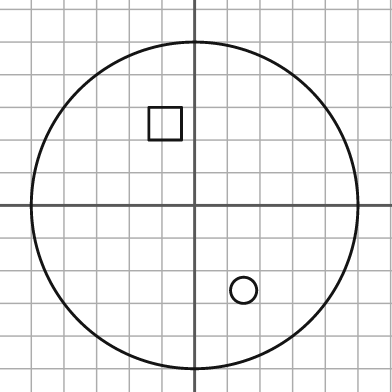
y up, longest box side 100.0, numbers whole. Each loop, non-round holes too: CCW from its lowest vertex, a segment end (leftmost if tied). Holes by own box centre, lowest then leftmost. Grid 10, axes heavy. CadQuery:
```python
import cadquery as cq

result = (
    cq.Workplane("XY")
    .moveTo(0.0, 0.0)
    .circle(50.0)
    .moveTo(15.0, -26.0)
    .circle(4.0)
    .moveTo(-14.0, 20.0)
    .lineTo(-4.0, 20.0)
    .lineTo(-4.0, 30.0)
    .lineTo(-14.0, 30.0)
    .close()
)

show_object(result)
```